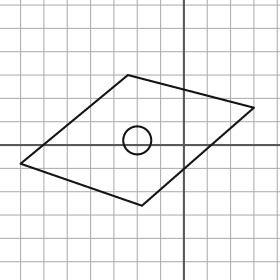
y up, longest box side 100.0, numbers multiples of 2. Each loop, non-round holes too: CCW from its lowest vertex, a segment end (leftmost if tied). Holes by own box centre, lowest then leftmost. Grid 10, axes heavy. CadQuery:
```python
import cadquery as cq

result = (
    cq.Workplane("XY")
    .moveTo(-18.0, -26.0)
    .lineTo(30.0, 16.0)
    .lineTo(-24.0, 30.0)
    .lineTo(-70.0, -8.0)
    .close()
    .moveTo(-20.0, 2.0)
    .circle(6.0)
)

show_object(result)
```